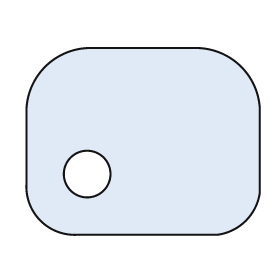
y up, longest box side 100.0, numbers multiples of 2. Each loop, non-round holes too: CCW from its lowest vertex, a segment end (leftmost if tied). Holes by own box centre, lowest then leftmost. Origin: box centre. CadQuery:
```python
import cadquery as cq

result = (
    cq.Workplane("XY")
    .moveTo(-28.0, -40.0)
    .lineTo(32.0, -40.0)
    .threePointArc((44.0, -34.0), (50.0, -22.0))
    .lineTo(50.0, 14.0)
    .threePointArc((42.0, 32.0), (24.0, 40.0))
    .lineTo(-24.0, 40.0)
    .threePointArc((-42.0, 32.0), (-50.0, 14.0))
    .lineTo(-50.0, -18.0)
    .threePointArc((-44.0, -34.0), (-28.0, -40.0))
    .close()
    .moveTo(-24.0, -14.0)
    .circle(10.0)
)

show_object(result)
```